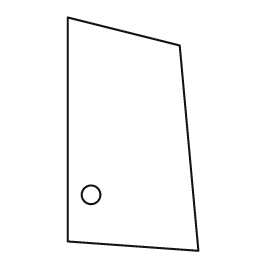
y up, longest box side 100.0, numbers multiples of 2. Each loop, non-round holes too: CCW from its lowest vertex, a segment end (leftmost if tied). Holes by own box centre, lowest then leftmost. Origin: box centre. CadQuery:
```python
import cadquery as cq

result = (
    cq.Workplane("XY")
    .moveTo(28.0, -50.0)
    .lineTo(20.0, 38.0)
    .lineTo(-28.0, 50.0)
    .lineTo(-28.0, -46.0)
    .close()
    .moveTo(-18.0, -26.0)
    .circle(4.0)
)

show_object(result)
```